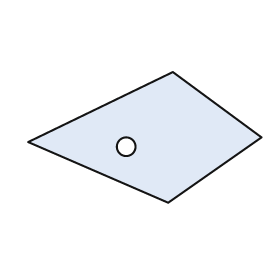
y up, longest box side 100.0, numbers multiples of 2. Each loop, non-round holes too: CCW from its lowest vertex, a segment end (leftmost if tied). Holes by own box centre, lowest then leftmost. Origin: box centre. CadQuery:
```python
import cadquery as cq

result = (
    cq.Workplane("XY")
    .moveTo(10.0, -28.0)
    .lineTo(50.0, 0.0)
    .lineTo(12.0, 28.0)
    .lineTo(-50.0, -2.0)
    .close()
    .moveTo(-8.0, -4.0)
    .circle(4.0)
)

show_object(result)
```